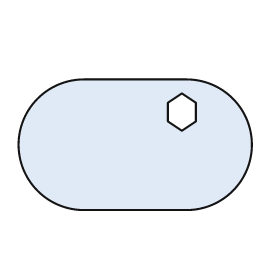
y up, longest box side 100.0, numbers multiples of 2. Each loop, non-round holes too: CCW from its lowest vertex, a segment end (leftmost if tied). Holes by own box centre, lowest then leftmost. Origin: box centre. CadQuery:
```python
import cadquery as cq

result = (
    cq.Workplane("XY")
    .moveTo(-22.0, -28.0)
    .lineTo(22.0, -28.0)
    .threePointArc((50.0, 0.0), (22.0, 28.0))
    .lineTo(-22.0, 28.0)
    .threePointArc((-50.0, 0.0), (-22.0, -28.0))
    .close()
    .moveTo(20.0, 6.0)
    .lineTo(26.0, 10.0)
    .lineTo(26.0, 18.0)
    .lineTo(20.0, 22.0)
    .lineTo(14.0, 18.0)
    .lineTo(14.0, 10.0)
    .close()
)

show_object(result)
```